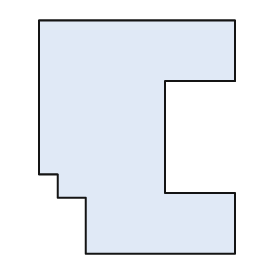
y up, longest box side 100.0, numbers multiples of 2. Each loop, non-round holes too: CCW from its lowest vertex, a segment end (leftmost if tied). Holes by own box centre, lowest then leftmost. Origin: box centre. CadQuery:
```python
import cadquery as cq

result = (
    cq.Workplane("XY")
    .moveTo(-22.0, -50.0)
    .lineTo(42.0, -50.0)
    .lineTo(42.0, -24.0)
    .lineTo(12.0, -24.0)
    .lineTo(12.0, 24.0)
    .lineTo(42.0, 24.0)
    .lineTo(42.0, 50.0)
    .lineTo(-42.0, 50.0)
    .lineTo(-42.0, -16.0)
    .lineTo(-34.0, -16.0)
    .lineTo(-34.0, -26.0)
    .lineTo(-22.0, -26.0)
    .close()
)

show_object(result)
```